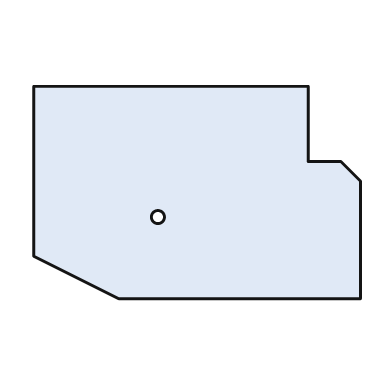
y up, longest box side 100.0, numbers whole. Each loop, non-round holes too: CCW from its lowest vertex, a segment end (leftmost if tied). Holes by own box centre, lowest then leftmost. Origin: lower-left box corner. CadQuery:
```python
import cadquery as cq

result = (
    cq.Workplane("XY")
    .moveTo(26.0, 0.0)
    .lineTo(100.0, 0.0)
    .lineTo(100.0, 36.0)
    .lineTo(94.0, 42.0)
    .lineTo(84.0, 42.0)
    .lineTo(84.0, 65.0)
    .lineTo(0.0, 65.0)
    .lineTo(0.0, 13.0)
    .close()
    .moveTo(38.0, 25.0)
    .circle(2.0)
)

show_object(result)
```